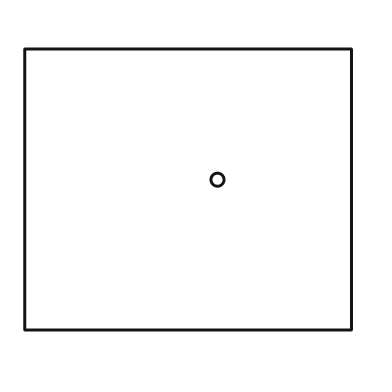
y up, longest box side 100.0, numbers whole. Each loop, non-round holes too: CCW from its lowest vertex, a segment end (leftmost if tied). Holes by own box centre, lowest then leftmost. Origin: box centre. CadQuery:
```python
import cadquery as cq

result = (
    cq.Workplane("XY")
    .moveTo(-50.0, -43.0)
    .lineTo(50.0, -43.0)
    .lineTo(50.0, 43.0)
    .lineTo(-50.0, 43.0)
    .close()
    .moveTo(9.0, 3.0)
    .circle(2.0)
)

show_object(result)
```